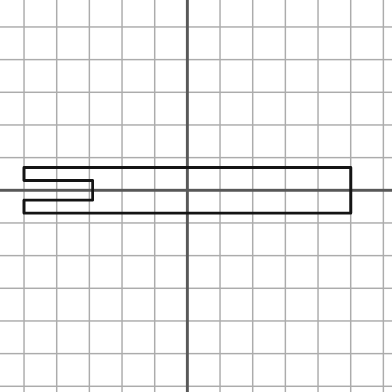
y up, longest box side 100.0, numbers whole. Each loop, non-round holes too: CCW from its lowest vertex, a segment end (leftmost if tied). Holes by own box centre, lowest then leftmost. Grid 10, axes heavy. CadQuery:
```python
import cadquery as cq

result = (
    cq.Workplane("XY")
    .moveTo(-50.0, -7.0)
    .lineTo(50.0, -7.0)
    .lineTo(50.0, 7.0)
    .lineTo(-50.0, 7.0)
    .lineTo(-50.0, 3.0)
    .lineTo(-29.0, 3.0)
    .lineTo(-29.0, -3.0)
    .lineTo(-50.0, -3.0)
    .close()
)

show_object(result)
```